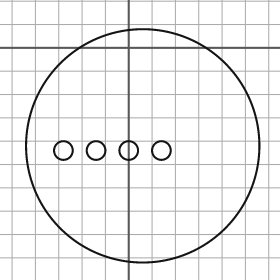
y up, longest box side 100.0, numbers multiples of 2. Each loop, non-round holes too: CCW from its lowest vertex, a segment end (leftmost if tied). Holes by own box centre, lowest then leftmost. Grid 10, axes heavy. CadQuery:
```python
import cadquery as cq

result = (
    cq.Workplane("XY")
    .moveTo(6.0, -42.0)
    .circle(50.0)
    .moveTo(-28.0, -44.0)
    .circle(4.0)
    .moveTo(-14.0, -44.0)
    .circle(4.0)
    .moveTo(0.0, -44.0)
    .circle(4.0)
    .moveTo(14.0, -44.0)
    .circle(4.0)
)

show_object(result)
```